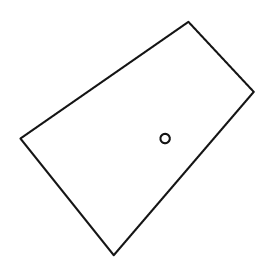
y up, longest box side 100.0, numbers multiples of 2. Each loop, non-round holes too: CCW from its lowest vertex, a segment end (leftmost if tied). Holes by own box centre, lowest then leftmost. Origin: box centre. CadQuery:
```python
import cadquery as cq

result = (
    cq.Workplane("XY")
    .moveTo(-10.0, -50.0)
    .lineTo(50.0, 20.0)
    .lineTo(22.0, 50.0)
    .lineTo(-50.0, 0.0)
    .close()
    .moveTo(12.0, 0.0)
    .circle(2.0)
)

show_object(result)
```